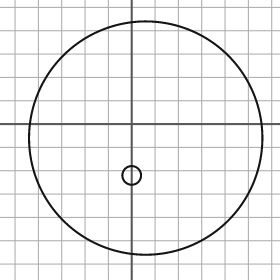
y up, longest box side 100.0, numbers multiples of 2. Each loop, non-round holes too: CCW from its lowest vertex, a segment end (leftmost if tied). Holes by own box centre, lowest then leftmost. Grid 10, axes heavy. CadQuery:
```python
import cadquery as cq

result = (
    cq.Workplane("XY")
    .moveTo(6.0, -6.0)
    .circle(50.0)
    .moveTo(0.0, -22.0)
    .circle(4.0)
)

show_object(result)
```